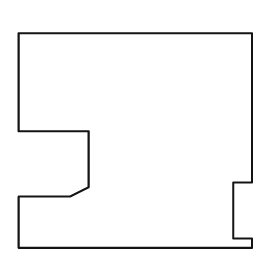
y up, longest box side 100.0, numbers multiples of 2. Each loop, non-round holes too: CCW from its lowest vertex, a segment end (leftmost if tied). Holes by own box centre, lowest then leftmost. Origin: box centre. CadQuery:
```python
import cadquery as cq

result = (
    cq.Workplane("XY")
    .moveTo(-50.0, -46.0)
    .lineTo(50.0, -46.0)
    .lineTo(50.0, -42.0)
    .lineTo(42.0, -42.0)
    .lineTo(42.0, -18.0)
    .lineTo(50.0, -18.0)
    .lineTo(50.0, 46.0)
    .lineTo(-50.0, 46.0)
    .lineTo(-50.0, 4.0)
    .lineTo(-20.0, 4.0)
    .lineTo(-20.0, -20.0)
    .lineTo(-28.0, -24.0)
    .lineTo(-50.0, -24.0)
    .close()
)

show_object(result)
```